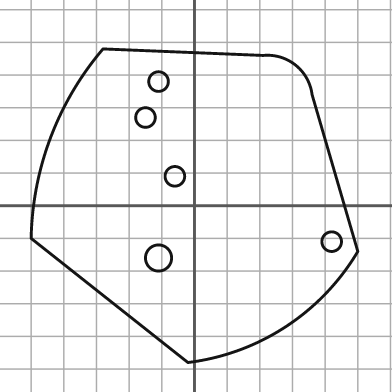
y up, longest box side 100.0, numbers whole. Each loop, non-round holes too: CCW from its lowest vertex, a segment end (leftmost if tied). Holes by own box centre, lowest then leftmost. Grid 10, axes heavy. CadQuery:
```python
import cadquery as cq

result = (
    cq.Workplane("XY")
    .moveTo(-2.0, -48.0)
    .threePointArc((28.0, -37.0), (50.0, -14.0))
    .lineTo(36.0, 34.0)
    .threePointArc((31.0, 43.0), (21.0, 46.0))
    .lineTo(-28.0, 48.0)
    .threePointArc((-44.0, 21.0), (-50.0, -10.0))
    .close()
    .moveTo(-11.0, -16.0)
    .circle(4.0)
    .moveTo(42.0, -11.0)
    .circle(3.0)
    .moveTo(-6.0, 9.0)
    .circle(3.0)
    .moveTo(-15.0, 27.0)
    .circle(3.0)
    .moveTo(-11.0, 38.0)
    .circle(3.0)
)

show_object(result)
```